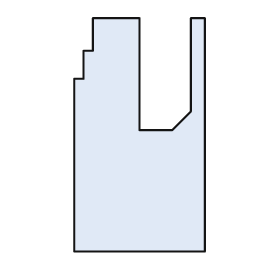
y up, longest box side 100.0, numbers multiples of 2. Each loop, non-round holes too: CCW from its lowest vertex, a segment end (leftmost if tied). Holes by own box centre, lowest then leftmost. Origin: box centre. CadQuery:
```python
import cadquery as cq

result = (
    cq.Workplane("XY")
    .moveTo(-28.0, -50.0)
    .lineTo(28.0, -50.0)
    .lineTo(28.0, 50.0)
    .lineTo(22.0, 50.0)
    .lineTo(22.0, 10.0)
    .lineTo(14.0, 2.0)
    .lineTo(0.0, 2.0)
    .lineTo(0.0, 50.0)
    .lineTo(-20.0, 50.0)
    .lineTo(-20.0, 36.0)
    .lineTo(-24.0, 36.0)
    .lineTo(-24.0, 24.0)
    .lineTo(-28.0, 24.0)
    .close()
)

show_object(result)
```